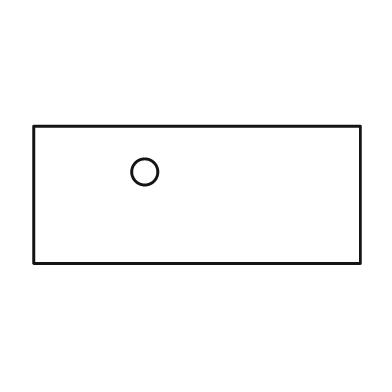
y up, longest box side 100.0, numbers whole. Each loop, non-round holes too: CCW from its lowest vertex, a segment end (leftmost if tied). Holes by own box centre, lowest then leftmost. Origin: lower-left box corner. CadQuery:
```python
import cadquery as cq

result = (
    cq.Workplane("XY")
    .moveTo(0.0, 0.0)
    .lineTo(100.0, 0.0)
    .lineTo(100.0, 42.0)
    .lineTo(0.0, 42.0)
    .close()
    .moveTo(34.0, 28.0)
    .circle(4.0)
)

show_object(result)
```